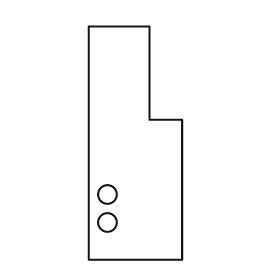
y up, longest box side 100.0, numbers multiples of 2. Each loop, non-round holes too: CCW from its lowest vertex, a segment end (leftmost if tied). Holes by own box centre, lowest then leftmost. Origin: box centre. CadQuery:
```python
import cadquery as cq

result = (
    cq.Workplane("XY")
    .moveTo(-20.0, -50.0)
    .lineTo(20.0, -50.0)
    .lineTo(20.0, 10.0)
    .lineTo(6.0, 10.0)
    .lineTo(6.0, 50.0)
    .lineTo(-20.0, 50.0)
    .close()
    .moveTo(-12.0, -34.0)
    .circle(4.0)
    .moveTo(-12.0, -22.0)
    .circle(4.0)
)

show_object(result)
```